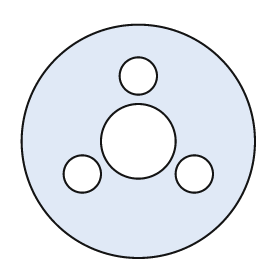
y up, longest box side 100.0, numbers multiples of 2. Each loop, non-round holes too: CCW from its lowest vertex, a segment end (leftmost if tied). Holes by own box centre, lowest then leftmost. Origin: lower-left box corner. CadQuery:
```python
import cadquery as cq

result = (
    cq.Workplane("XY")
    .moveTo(50.0, 50.0)
    .circle(50.0)
    .moveTo(26.0, 36.0)
    .circle(8.0)
    .moveTo(74.0, 36.0)
    .circle(8.0)
    .moveTo(50.0, 50.0)
    .circle(16.0)
    .moveTo(50.0, 78.0)
    .circle(8.0)
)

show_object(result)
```